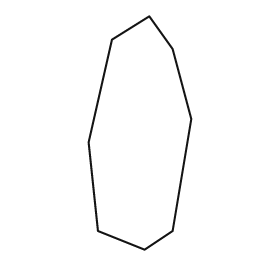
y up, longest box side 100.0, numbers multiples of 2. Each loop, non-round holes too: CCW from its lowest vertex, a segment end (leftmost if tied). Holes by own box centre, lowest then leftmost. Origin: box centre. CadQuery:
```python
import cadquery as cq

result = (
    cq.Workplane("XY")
    .moveTo(2.0, -50.0)
    .lineTo(14.0, -42.0)
    .lineTo(22.0, 6.0)
    .lineTo(14.0, 36.0)
    .lineTo(4.0, 50.0)
    .lineTo(-12.0, 40.0)
    .lineTo(-22.0, -4.0)
    .lineTo(-18.0, -42.0)
    .close()
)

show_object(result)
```